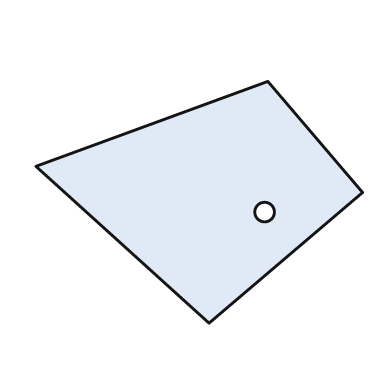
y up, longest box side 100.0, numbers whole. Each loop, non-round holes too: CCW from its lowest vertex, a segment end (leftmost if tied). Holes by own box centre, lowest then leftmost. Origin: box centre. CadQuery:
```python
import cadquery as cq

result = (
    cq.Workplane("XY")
    .moveTo(3.0, -37.0)
    .lineTo(50.0, 3.0)
    .lineTo(21.0, 37.0)
    .lineTo(-50.0, 11.0)
    .close()
    .moveTo(20.0, -3.0)
    .circle(3.0)
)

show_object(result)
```